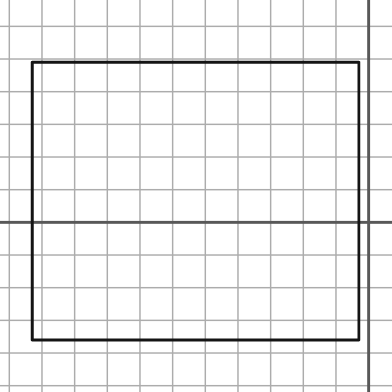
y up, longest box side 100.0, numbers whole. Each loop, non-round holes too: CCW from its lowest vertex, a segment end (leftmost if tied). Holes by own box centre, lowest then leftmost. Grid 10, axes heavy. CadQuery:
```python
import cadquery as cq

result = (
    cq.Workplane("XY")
    .moveTo(-103.0, -36.0)
    .lineTo(-3.0, -36.0)
    .lineTo(-3.0, 49.0)
    .lineTo(-103.0, 49.0)
    .close()
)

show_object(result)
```